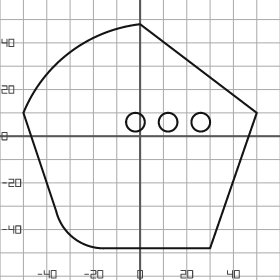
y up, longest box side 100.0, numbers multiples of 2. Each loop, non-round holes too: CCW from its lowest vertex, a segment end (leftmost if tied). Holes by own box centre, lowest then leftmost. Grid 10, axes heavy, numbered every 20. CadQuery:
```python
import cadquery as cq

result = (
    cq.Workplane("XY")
    .moveTo(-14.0, -48.0)
    .lineTo(30.0, -48.0)
    .lineTo(50.0, 10.0)
    .lineTo(0.0, 48.0)
    .threePointArc((-30.0, 36.0), (-50.0, 10.0))
    .lineTo(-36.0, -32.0)
    .threePointArc((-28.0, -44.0), (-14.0, -48.0))
    .close()
    .moveTo(-2.0, 6.0)
    .circle(4.0)
    .moveTo(12.0, 6.0)
    .circle(4.0)
    .moveTo(26.0, 6.0)
    .circle(4.0)
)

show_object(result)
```